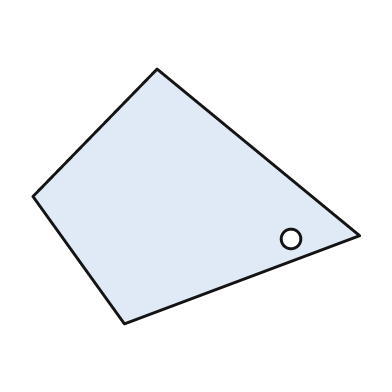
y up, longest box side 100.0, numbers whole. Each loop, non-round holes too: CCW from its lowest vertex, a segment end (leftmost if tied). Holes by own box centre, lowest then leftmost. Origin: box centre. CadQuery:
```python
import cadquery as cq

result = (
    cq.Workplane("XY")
    .moveTo(-22.0, -39.0)
    .lineTo(50.0, -12.0)
    .lineTo(-12.0, 39.0)
    .lineTo(-50.0, 0.0)
    .close()
    .moveTo(29.0, -13.0)
    .circle(3.0)
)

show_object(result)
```